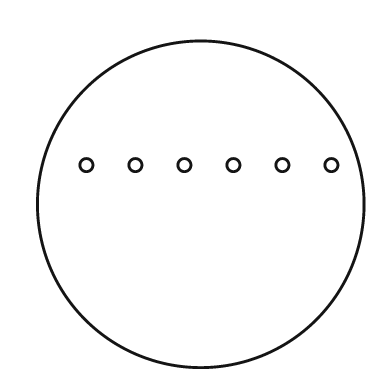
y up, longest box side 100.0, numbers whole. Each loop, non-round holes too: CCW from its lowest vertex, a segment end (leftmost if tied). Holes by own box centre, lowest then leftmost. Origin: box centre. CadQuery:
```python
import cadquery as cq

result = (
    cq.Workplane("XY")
    .moveTo(0.0, 0.0)
    .circle(50.0)
    .moveTo(-35.0, 12.0)
    .circle(2.0)
    .moveTo(-20.0, 12.0)
    .circle(2.0)
    .moveTo(-5.0, 12.0)
    .circle(2.0)
    .moveTo(10.0, 12.0)
    .circle(2.0)
    .moveTo(25.0, 12.0)
    .circle(2.0)
    .moveTo(40.0, 12.0)
    .circle(2.0)
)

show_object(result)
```